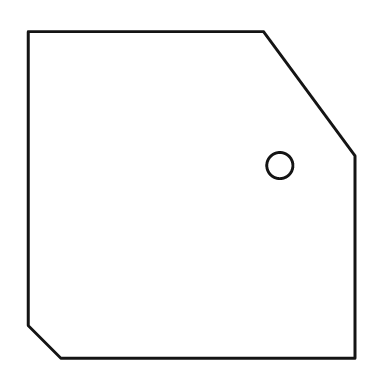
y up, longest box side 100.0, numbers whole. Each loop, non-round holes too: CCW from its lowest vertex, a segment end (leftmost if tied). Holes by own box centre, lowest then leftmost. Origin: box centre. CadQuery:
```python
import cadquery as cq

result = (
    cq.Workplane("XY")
    .moveTo(-40.0, -50.0)
    .lineTo(50.0, -50.0)
    .lineTo(50.0, 12.0)
    .lineTo(22.0, 50.0)
    .lineTo(-50.0, 50.0)
    .lineTo(-50.0, -40.0)
    .close()
    .moveTo(27.0, 9.0)
    .circle(4.0)
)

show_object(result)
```